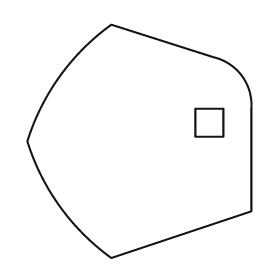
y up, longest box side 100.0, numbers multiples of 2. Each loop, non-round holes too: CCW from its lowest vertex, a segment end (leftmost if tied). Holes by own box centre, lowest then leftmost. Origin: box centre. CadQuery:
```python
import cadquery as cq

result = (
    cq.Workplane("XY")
    .moveTo(-12.0, -50.0)
    .lineTo(48.0, -30.0)
    .lineTo(48.0, 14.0)
    .threePointArc((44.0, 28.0), (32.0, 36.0))
    .lineTo(-12.0, 50.0)
    .threePointArc((-34.0, 28.0), (-48.0, 0.0))
    .threePointArc((-34.0, -28.0), (-12.0, -50.0))
    .close()
    .moveTo(24.0, 2.0)
    .lineTo(36.0, 2.0)
    .lineTo(36.0, 14.0)
    .lineTo(24.0, 14.0)
    .close()
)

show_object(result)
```